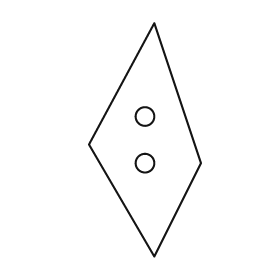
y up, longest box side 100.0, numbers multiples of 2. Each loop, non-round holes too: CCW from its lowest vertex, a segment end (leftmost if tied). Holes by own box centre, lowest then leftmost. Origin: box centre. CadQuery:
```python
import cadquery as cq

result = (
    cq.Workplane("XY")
    .moveTo(4.0, -50.0)
    .lineTo(24.0, -10.0)
    .lineTo(4.0, 50.0)
    .lineTo(-24.0, -2.0)
    .close()
    .moveTo(0.0, -10.0)
    .circle(4.0)
    .moveTo(0.0, 10.0)
    .circle(4.0)
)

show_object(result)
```